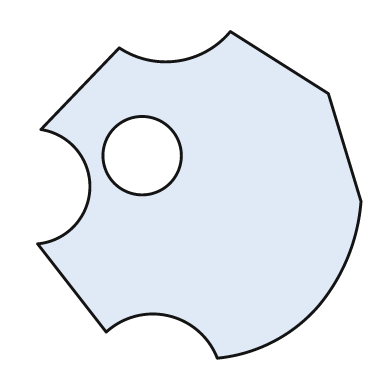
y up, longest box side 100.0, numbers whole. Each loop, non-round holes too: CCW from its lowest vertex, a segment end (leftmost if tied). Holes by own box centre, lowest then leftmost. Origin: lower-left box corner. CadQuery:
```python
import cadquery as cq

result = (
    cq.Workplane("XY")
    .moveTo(55.0, 0.0)
    .threePointArc((72.0, 5.0), (86.0, 16.0))
    .threePointArc((95.0, 31.0), (99.0, 48.0))
    .lineTo(89.0, 81.0)
    .lineTo(59.0, 100.0)
    .threePointArc((43.0, 91.0), (25.0, 95.0))
    .lineTo(1.0, 70.0)
    .threePointArc((16.0, 52.0), (0.0, 35.0))
    .lineTo(21.0, 8.0)
    .threePointArc((40.0, 13.0), (55.0, 0.0))
    .close()
    .moveTo(32.0, 62.0)
    .circle(12.0)
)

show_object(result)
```